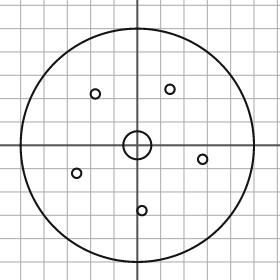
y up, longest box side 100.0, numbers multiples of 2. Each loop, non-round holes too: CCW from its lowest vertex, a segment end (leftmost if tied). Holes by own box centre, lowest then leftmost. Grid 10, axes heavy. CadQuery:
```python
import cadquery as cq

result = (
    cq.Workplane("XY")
    .moveTo(0.0, 0.0)
    .circle(50.0)
    .moveTo(2.0, -28.0)
    .circle(2.0)
    .moveTo(-26.0, -12.0)
    .circle(2.0)
    .moveTo(28.0, -6.0)
    .circle(2.0)
    .moveTo(0.0, 0.0)
    .circle(6.0)
    .moveTo(-18.0, 22.0)
    .circle(2.0)
    .moveTo(14.0, 24.0)
    .circle(2.0)
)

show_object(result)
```